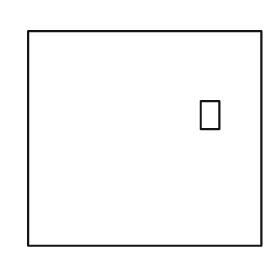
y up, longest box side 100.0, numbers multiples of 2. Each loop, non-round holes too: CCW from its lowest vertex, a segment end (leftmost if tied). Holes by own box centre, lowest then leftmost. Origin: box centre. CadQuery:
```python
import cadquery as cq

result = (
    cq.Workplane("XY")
    .moveTo(-50.0, -46.0)
    .lineTo(50.0, -46.0)
    .lineTo(50.0, 46.0)
    .lineTo(-50.0, 46.0)
    .close()
    .moveTo(24.0, 4.0)
    .lineTo(32.0, 4.0)
    .lineTo(32.0, 16.0)
    .lineTo(24.0, 16.0)
    .close()
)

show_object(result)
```